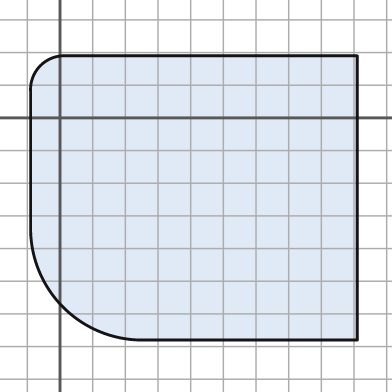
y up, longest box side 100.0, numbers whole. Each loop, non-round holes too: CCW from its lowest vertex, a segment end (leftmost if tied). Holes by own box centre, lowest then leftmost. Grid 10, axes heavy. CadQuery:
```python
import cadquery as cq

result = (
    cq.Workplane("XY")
    .moveTo(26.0, -68.0)
    .lineTo(91.0, -68.0)
    .lineTo(91.0, 19.0)
    .lineTo(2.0, 19.0)
    .threePointArc((-6.0, 16.0), (-9.0, 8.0))
    .lineTo(-9.0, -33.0)
    .threePointArc((1.0, -58.0), (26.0, -68.0))
    .close()
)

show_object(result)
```